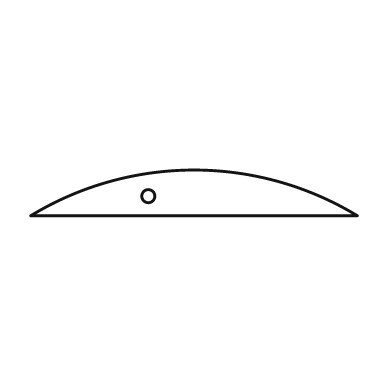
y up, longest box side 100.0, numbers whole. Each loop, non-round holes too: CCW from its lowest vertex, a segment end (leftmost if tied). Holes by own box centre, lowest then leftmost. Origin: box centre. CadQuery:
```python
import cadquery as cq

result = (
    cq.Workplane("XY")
    .moveTo(-50.0, -7.0)
    .lineTo(50.0, -7.0)
    .threePointArc((0.0, 7.0), (-50.0, -7.0))
    .close()
    .moveTo(-14.0, -1.0)
    .circle(2.0)
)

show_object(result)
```